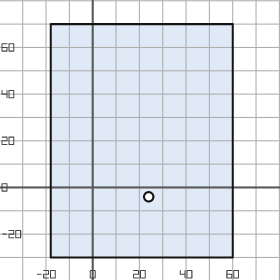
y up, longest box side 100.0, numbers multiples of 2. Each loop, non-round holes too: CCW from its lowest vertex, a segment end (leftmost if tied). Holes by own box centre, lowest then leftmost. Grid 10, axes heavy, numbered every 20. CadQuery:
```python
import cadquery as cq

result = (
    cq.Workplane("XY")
    .moveTo(-18.0, -30.0)
    .lineTo(60.0, -30.0)
    .lineTo(60.0, 70.0)
    .lineTo(-18.0, 70.0)
    .close()
    .moveTo(24.0, -4.0)
    .circle(2.0)
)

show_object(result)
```